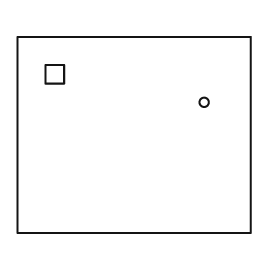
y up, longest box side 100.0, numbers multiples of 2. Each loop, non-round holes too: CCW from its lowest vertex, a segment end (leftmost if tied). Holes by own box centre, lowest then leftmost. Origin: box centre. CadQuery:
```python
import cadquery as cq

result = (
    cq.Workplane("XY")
    .moveTo(-50.0, -42.0)
    .lineTo(50.0, -42.0)
    .lineTo(50.0, 42.0)
    .lineTo(-50.0, 42.0)
    .close()
    .moveTo(30.0, 14.0)
    .circle(2.0)
    .moveTo(-38.0, 22.0)
    .lineTo(-30.0, 22.0)
    .lineTo(-30.0, 30.0)
    .lineTo(-38.0, 30.0)
    .close()
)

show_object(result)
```